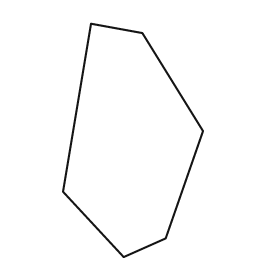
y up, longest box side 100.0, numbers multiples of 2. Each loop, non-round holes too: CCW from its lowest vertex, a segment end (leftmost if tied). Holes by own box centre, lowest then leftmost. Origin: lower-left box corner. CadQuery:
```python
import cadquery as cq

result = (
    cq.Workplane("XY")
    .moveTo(26.0, 0.0)
    .lineTo(44.0, 8.0)
    .lineTo(60.0, 54.0)
    .lineTo(34.0, 96.0)
    .lineTo(12.0, 100.0)
    .lineTo(0.0, 28.0)
    .close()
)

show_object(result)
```